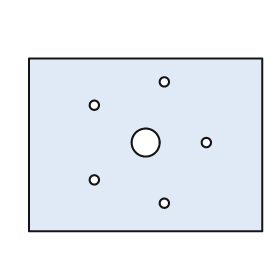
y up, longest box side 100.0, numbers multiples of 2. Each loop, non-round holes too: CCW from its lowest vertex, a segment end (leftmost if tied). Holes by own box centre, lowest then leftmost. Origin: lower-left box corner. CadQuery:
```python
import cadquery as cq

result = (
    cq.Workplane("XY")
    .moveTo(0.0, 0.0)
    .lineTo(100.0, 0.0)
    .lineTo(100.0, 74.0)
    .lineTo(0.0, 74.0)
    .close()
    .moveTo(58.0, 12.0)
    .circle(2.0)
    .moveTo(28.0, 22.0)
    .circle(2.0)
    .moveTo(50.0, 38.0)
    .circle(6.0)
    .moveTo(76.0, 38.0)
    .circle(2.0)
    .moveTo(28.0, 54.0)
    .circle(2.0)
    .moveTo(58.0, 64.0)
    .circle(2.0)
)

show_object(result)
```